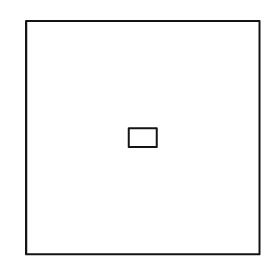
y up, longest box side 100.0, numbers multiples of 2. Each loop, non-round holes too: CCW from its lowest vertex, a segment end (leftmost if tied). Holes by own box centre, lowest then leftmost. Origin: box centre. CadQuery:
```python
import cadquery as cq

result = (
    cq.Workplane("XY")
    .moveTo(-50.0, -50.0)
    .lineTo(50.0, -50.0)
    .lineTo(50.0, 50.0)
    .lineTo(-50.0, 50.0)
    .close()
    .moveTo(-6.0, -4.0)
    .lineTo(6.0, -4.0)
    .lineTo(6.0, 4.0)
    .lineTo(-6.0, 4.0)
    .close()
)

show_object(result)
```